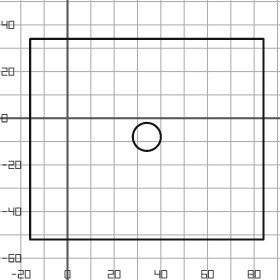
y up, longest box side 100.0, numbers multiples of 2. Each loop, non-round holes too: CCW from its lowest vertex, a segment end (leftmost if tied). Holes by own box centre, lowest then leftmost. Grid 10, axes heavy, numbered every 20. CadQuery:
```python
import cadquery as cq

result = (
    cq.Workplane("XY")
    .moveTo(-16.0, -52.0)
    .lineTo(84.0, -52.0)
    .lineTo(84.0, 34.0)
    .lineTo(-16.0, 34.0)
    .close()
    .moveTo(34.0, -8.0)
    .circle(6.0)
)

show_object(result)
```